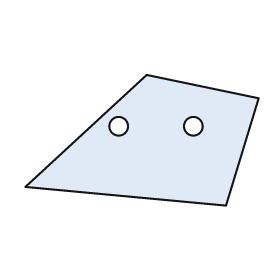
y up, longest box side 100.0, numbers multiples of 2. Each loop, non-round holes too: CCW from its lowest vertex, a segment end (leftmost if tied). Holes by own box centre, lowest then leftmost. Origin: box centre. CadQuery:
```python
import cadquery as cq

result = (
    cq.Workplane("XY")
    .moveTo(36.0, -28.0)
    .lineTo(50.0, 18.0)
    .lineTo(2.0, 28.0)
    .lineTo(-50.0, -20.0)
    .close()
    .moveTo(-10.0, 6.0)
    .circle(4.0)
    .moveTo(22.0, 6.0)
    .circle(4.0)
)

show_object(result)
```